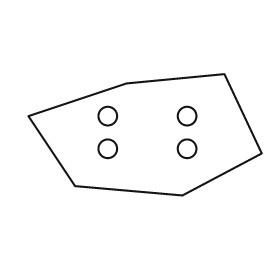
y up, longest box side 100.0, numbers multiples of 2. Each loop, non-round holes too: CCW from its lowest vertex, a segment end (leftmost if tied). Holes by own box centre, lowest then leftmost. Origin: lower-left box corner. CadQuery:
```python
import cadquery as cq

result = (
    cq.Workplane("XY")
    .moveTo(66.0, 0.0)
    .lineTo(100.0, 18.0)
    .lineTo(84.0, 52.0)
    .lineTo(42.0, 48.0)
    .lineTo(0.0, 34.0)
    .lineTo(20.0, 4.0)
    .close()
    .moveTo(34.0, 20.0)
    .circle(4.0)
    .moveTo(68.0, 20.0)
    .circle(4.0)
    .moveTo(34.0, 34.0)
    .circle(4.0)
    .moveTo(68.0, 34.0)
    .circle(4.0)
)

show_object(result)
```